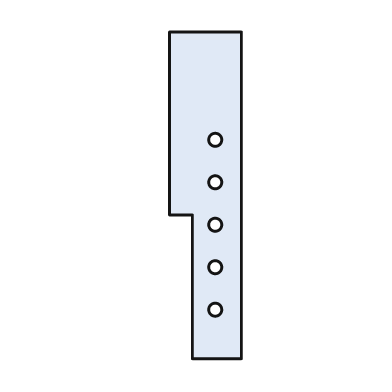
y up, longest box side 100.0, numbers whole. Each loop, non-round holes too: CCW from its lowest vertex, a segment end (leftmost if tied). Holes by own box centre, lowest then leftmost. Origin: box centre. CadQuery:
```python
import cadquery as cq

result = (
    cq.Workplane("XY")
    .moveTo(-4.0, -50.0)
    .lineTo(11.0, -50.0)
    .lineTo(11.0, 50.0)
    .lineTo(-11.0, 50.0)
    .lineTo(-11.0, -6.0)
    .lineTo(-4.0, -6.0)
    .close()
    .moveTo(3.0, -35.0)
    .circle(2.0)
    .moveTo(3.0, -22.0)
    .circle(2.0)
    .moveTo(3.0, -9.0)
    .circle(2.0)
    .moveTo(3.0, 4.0)
    .circle(2.0)
    .moveTo(3.0, 17.0)
    .circle(2.0)
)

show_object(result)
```